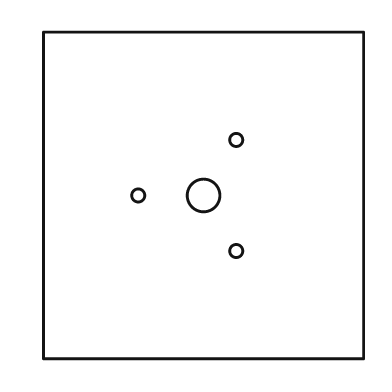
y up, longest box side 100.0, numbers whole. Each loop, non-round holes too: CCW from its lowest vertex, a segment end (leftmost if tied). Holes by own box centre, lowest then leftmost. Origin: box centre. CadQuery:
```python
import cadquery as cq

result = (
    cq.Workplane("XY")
    .moveTo(-49.0, -50.0)
    .lineTo(49.0, -50.0)
    .lineTo(49.0, 50.0)
    .lineTo(-49.0, 50.0)
    .close()
    .moveTo(10.0, -17.0)
    .circle(2.0)
    .moveTo(-20.0, 0.0)
    .circle(2.0)
    .moveTo(0.0, 0.0)
    .circle(5.0)
    .moveTo(10.0, 17.0)
    .circle(2.0)
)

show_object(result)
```